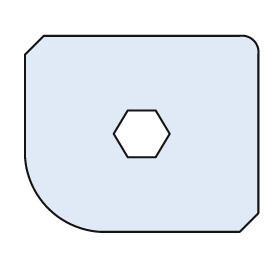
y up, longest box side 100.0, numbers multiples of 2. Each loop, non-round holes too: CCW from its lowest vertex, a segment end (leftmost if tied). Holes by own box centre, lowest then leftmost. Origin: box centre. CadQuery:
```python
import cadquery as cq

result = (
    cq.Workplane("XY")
    .moveTo(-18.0, -42.0)
    .lineTo(42.0, -42.0)
    .lineTo(50.0, -34.0)
    .lineTo(50.0, 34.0)
    .threePointArc((48.0, 40.0), (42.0, 42.0))
    .lineTo(-42.0, 42.0)
    .lineTo(-50.0, 34.0)
    .lineTo(-50.0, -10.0)
    .threePointArc((-40.0, -32.0), (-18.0, -42.0))
    .close()
    .moveTo(-6.0, -10.0)
    .lineTo(6.0, -10.0)
    .lineTo(12.0, 0.0)
    .lineTo(6.0, 10.0)
    .lineTo(-6.0, 10.0)
    .lineTo(-12.0, 0.0)
    .close()
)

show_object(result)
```